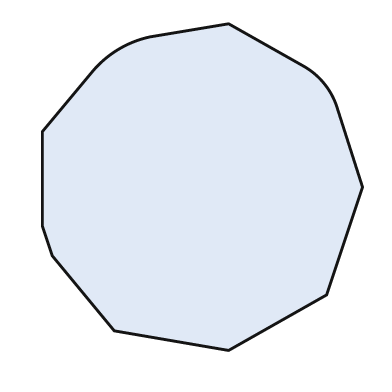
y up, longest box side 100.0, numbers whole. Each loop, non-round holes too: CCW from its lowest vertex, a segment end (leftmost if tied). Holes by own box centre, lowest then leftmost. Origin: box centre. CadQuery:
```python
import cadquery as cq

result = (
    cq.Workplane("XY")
    .moveTo(8.0, -50.0)
    .lineTo(38.0, -33.0)
    .lineTo(49.0, 0.0)
    .lineTo(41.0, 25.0)
    .threePointArc((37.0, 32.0), (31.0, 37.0))
    .lineTo(8.0, 50.0)
    .lineTo(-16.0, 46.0)
    .threePointArc((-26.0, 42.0), (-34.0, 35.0))
    .lineTo(-49.0, 17.0)
    .lineTo(-49.0, -12.0)
    .lineTo(-46.0, -21.0)
    .lineTo(-27.0, -44.0)
    .close()
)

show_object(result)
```